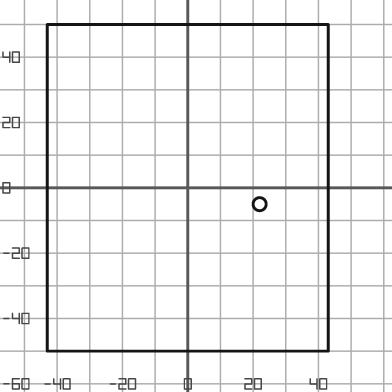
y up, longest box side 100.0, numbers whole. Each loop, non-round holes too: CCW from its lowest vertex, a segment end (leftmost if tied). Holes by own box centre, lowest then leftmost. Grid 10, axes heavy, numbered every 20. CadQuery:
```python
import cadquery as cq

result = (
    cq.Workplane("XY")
    .moveTo(-43.0, -50.0)
    .lineTo(43.0, -50.0)
    .lineTo(43.0, 50.0)
    .lineTo(-43.0, 50.0)
    .close()
    .moveTo(22.0, -5.0)
    .circle(2.0)
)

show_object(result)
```